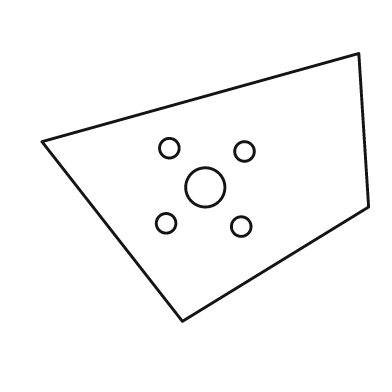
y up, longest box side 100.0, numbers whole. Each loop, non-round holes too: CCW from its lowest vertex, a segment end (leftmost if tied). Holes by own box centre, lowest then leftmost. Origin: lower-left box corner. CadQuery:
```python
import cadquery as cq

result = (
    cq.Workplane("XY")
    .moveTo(43.0, 0.0)
    .lineTo(100.0, 35.0)
    .lineTo(97.0, 82.0)
    .lineTo(0.0, 55.0)
    .close()
    .moveTo(61.0, 29.0)
    .circle(3.0)
    .moveTo(38.0, 30.0)
    .circle(3.0)
    .moveTo(50.0, 41.0)
    .circle(6.0)
    .moveTo(62.0, 52.0)
    .circle(3.0)
    .moveTo(39.0, 53.0)
    .circle(3.0)
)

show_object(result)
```